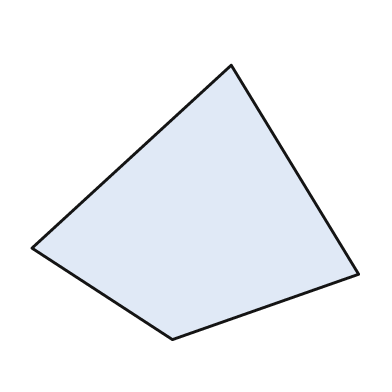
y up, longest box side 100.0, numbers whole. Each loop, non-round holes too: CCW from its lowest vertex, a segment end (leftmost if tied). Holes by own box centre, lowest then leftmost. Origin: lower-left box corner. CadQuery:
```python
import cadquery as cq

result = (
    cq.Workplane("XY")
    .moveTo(43.0, 0.0)
    .lineTo(100.0, 20.0)
    .lineTo(61.0, 84.0)
    .lineTo(0.0, 28.0)
    .close()
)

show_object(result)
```